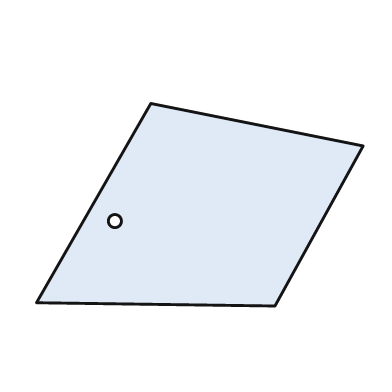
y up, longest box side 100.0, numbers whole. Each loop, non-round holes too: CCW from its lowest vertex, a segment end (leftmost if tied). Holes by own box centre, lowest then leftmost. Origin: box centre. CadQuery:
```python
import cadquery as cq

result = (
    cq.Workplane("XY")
    .moveTo(23.0, -31.0)
    .lineTo(50.0, 18.0)
    .lineTo(-15.0, 31.0)
    .lineTo(-50.0, -30.0)
    .close()
    .moveTo(-26.0, -5.0)
    .circle(2.0)
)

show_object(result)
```